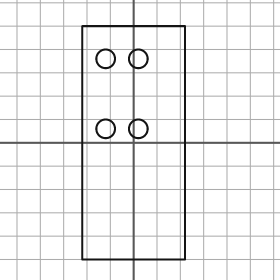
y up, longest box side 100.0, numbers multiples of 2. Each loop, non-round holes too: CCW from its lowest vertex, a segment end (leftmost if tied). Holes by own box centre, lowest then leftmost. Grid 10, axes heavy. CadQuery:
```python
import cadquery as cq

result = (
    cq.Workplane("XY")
    .moveTo(-22.0, -50.0)
    .lineTo(22.0, -50.0)
    .lineTo(22.0, 50.0)
    .lineTo(-22.0, 50.0)
    .close()
    .moveTo(-12.0, 6.0)
    .circle(4.0)
    .moveTo(2.0, 6.0)
    .circle(4.0)
    .moveTo(-12.0, 36.0)
    .circle(4.0)
    .moveTo(2.0, 36.0)
    .circle(4.0)
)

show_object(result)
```